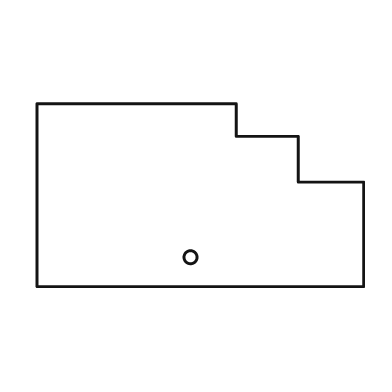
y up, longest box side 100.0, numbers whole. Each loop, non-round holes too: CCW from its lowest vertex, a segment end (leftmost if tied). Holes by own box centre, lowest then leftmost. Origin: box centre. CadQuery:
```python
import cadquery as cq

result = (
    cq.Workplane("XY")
    .moveTo(-50.0, -28.0)
    .lineTo(50.0, -28.0)
    .lineTo(50.0, 4.0)
    .lineTo(30.0, 4.0)
    .lineTo(30.0, 18.0)
    .lineTo(11.0, 18.0)
    .lineTo(11.0, 28.0)
    .lineTo(-50.0, 28.0)
    .close()
    .moveTo(-3.0, -19.0)
    .circle(2.0)
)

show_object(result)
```